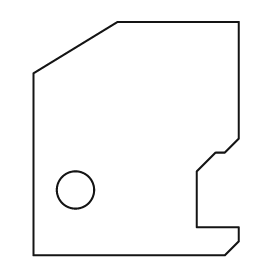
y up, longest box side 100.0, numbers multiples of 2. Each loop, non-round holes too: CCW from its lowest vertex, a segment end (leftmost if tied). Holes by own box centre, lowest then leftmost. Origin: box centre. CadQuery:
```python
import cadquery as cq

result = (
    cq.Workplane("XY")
    .moveTo(-44.0, -50.0)
    .lineTo(38.0, -50.0)
    .lineTo(44.0, -44.0)
    .lineTo(44.0, -38.0)
    .lineTo(26.0, -38.0)
    .lineTo(26.0, -14.0)
    .lineTo(34.0, -6.0)
    .lineTo(38.0, -6.0)
    .lineTo(44.0, 0.0)
    .lineTo(44.0, 50.0)
    .lineTo(-8.0, 50.0)
    .lineTo(-44.0, 28.0)
    .close()
    .moveTo(-26.0, -22.0)
    .circle(8.0)
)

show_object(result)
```